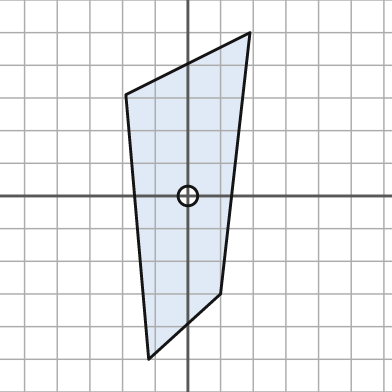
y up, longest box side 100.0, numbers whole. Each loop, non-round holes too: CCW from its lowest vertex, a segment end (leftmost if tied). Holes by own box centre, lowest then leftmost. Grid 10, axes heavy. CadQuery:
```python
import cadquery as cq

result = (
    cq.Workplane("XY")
    .moveTo(-12.0, -50.0)
    .lineTo(10.0, -30.0)
    .lineTo(19.0, 50.0)
    .lineTo(-19.0, 31.0)
    .close()
    .moveTo(0.0, 0.0)
    .circle(3.0)
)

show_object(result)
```